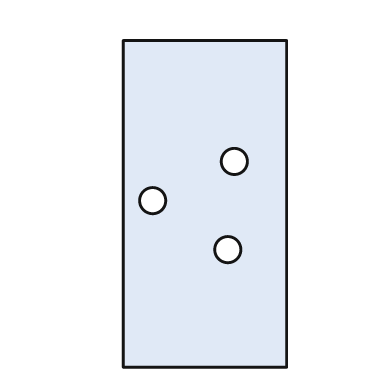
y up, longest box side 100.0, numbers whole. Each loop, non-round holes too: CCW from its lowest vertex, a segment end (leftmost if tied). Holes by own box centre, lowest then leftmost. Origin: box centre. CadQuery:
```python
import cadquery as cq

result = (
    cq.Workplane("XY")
    .moveTo(-25.0, -50.0)
    .lineTo(25.0, -50.0)
    .lineTo(25.0, 50.0)
    .lineTo(-25.0, 50.0)
    .close()
    .moveTo(7.0, -14.0)
    .circle(4.0)
    .moveTo(-16.0, 1.0)
    .circle(4.0)
    .moveTo(9.0, 13.0)
    .circle(4.0)
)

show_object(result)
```